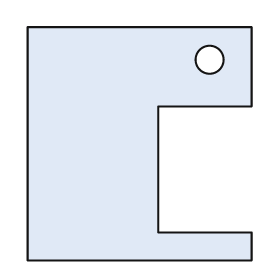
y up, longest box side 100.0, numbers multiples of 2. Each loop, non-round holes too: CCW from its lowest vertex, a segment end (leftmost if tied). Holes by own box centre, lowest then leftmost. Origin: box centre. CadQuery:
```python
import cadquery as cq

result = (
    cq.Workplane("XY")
    .moveTo(-48.0, -50.0)
    .lineTo(48.0, -50.0)
    .lineTo(48.0, -38.0)
    .lineTo(8.0, -38.0)
    .lineTo(8.0, 16.0)
    .lineTo(48.0, 16.0)
    .lineTo(48.0, 50.0)
    .lineTo(-48.0, 50.0)
    .close()
    .moveTo(30.0, 36.0)
    .circle(6.0)
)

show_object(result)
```